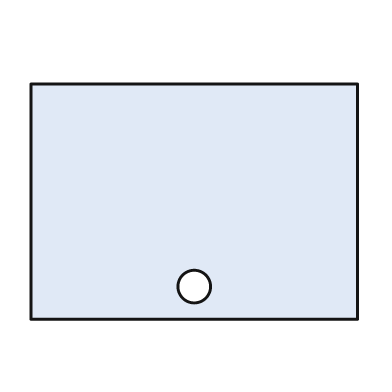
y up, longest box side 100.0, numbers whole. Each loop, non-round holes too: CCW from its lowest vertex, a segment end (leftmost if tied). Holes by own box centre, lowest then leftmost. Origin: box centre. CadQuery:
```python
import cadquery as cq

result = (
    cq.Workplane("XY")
    .moveTo(-50.0, -36.0)
    .lineTo(50.0, -36.0)
    .lineTo(50.0, 36.0)
    .lineTo(-50.0, 36.0)
    .close()
    .moveTo(0.0, -26.0)
    .circle(5.0)
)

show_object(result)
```